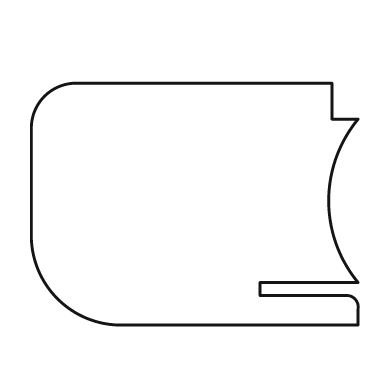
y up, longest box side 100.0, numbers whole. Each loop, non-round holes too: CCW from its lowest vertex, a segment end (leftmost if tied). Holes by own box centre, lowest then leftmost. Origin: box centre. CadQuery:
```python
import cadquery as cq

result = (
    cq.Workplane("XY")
    .moveTo(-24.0, -37.0)
    .lineTo(50.0, -37.0)
    .lineTo(50.0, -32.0)
    .threePointArc((49.0, -29.0), (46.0, -28.0))
    .lineTo(20.0, -28.0)
    .lineTo(20.0, -24.0)
    .lineTo(50.0, -24.0)
    .threePointArc((41.0, 1.0), (50.0, 26.0))
    .lineTo(42.0, 26.0)
    .lineTo(42.0, 37.0)
    .lineTo(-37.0, 37.0)
    .threePointArc((-46.0, 33.0), (-50.0, 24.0))
    .lineTo(-50.0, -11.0)
    .threePointArc((-42.0, -29.0), (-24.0, -37.0))
    .close()
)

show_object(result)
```